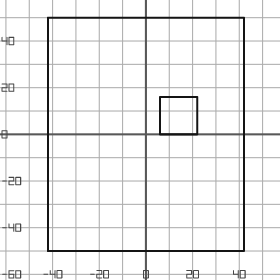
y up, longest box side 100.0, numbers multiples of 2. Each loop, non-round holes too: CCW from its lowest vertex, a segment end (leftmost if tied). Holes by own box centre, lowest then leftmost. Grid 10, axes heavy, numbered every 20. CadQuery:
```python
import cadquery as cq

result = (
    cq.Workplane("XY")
    .moveTo(-42.0, -50.0)
    .lineTo(42.0, -50.0)
    .lineTo(42.0, 50.0)
    .lineTo(-42.0, 50.0)
    .close()
    .moveTo(6.0, 0.0)
    .lineTo(22.0, 0.0)
    .lineTo(22.0, 16.0)
    .lineTo(6.0, 16.0)
    .close()
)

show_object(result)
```